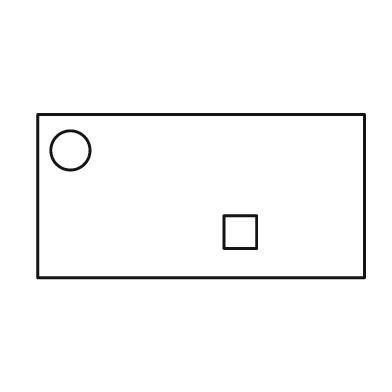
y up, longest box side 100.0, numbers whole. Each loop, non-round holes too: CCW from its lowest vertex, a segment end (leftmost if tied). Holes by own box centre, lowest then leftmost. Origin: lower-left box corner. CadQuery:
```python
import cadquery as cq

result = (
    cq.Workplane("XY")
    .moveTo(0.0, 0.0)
    .lineTo(100.0, 0.0)
    .lineTo(100.0, 50.0)
    .lineTo(0.0, 50.0)
    .close()
    .moveTo(57.0, 9.0)
    .lineTo(67.0, 9.0)
    .lineTo(67.0, 19.0)
    .lineTo(57.0, 19.0)
    .close()
    .moveTo(10.0, 39.0)
    .circle(6.0)
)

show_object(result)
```